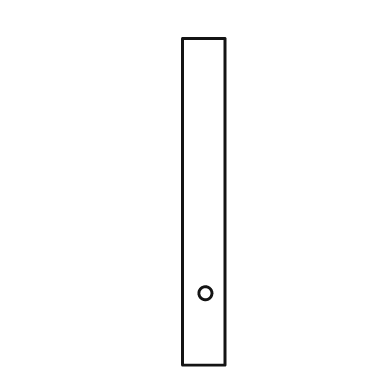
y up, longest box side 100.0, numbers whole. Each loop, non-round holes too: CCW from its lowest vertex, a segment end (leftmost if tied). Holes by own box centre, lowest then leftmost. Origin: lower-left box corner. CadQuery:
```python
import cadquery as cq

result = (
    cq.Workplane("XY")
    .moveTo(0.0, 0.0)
    .lineTo(13.0, 0.0)
    .lineTo(13.0, 100.0)
    .lineTo(0.0, 100.0)
    .close()
    .moveTo(7.0, 22.0)
    .circle(2.0)
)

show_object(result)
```